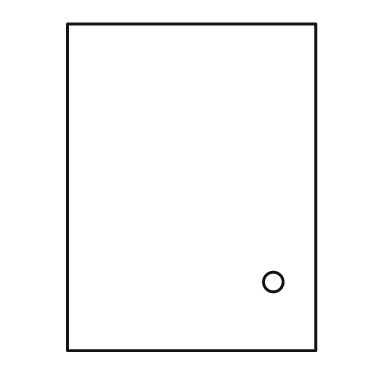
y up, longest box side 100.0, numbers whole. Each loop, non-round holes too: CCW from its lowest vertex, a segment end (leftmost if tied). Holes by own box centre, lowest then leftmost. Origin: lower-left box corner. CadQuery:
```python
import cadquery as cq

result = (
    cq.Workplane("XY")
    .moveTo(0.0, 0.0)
    .lineTo(76.0, 0.0)
    .lineTo(76.0, 100.0)
    .lineTo(0.0, 100.0)
    .close()
    .moveTo(63.0, 21.0)
    .circle(3.0)
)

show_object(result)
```